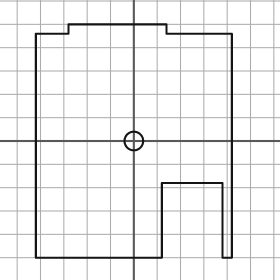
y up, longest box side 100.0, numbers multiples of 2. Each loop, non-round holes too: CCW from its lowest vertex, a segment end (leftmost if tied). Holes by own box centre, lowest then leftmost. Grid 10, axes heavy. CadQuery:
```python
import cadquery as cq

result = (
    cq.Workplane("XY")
    .moveTo(-42.0, -50.0)
    .lineTo(12.0, -50.0)
    .lineTo(12.0, -18.0)
    .lineTo(38.0, -18.0)
    .lineTo(38.0, -50.0)
    .lineTo(42.0, -50.0)
    .lineTo(42.0, 46.0)
    .lineTo(14.0, 46.0)
    .lineTo(14.0, 50.0)
    .lineTo(-28.0, 50.0)
    .lineTo(-28.0, 46.0)
    .lineTo(-42.0, 46.0)
    .close()
    .moveTo(0.0, 0.0)
    .circle(4.0)
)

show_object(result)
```